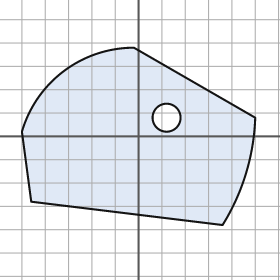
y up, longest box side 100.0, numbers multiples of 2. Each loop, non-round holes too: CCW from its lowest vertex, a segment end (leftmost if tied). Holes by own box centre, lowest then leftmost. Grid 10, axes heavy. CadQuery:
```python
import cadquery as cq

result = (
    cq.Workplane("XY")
    .moveTo(36.0, -38.0)
    .threePointArc((46.0, -16.0), (50.0, 8.0))
    .lineTo(-2.0, 38.0)
    .threePointArc((-32.0, 28.0), (-50.0, 2.0))
    .lineTo(-46.0, -28.0)
    .close()
    .moveTo(12.0, 8.0)
    .circle(6.0)
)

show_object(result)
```